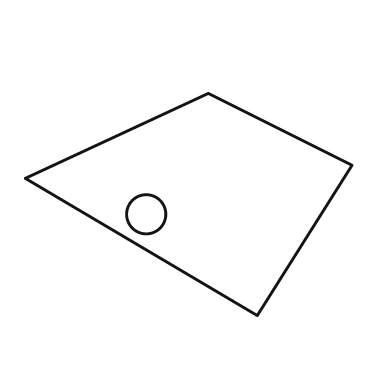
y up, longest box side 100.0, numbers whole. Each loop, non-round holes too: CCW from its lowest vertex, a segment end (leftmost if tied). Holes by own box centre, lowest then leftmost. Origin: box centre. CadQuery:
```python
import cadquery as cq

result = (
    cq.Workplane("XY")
    .moveTo(21.0, -34.0)
    .lineTo(50.0, 12.0)
    .lineTo(6.0, 34.0)
    .lineTo(-50.0, 8.0)
    .close()
    .moveTo(-13.0, -3.0)
    .circle(6.0)
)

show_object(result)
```